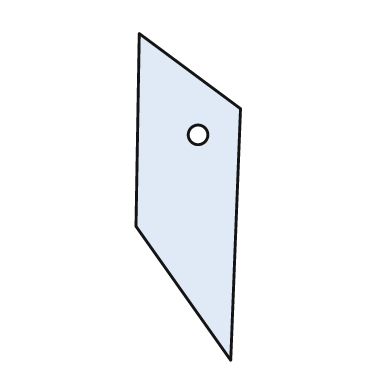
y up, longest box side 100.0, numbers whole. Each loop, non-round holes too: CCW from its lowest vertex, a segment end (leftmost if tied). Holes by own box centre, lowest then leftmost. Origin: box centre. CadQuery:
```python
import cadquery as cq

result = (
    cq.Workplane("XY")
    .moveTo(13.0, -50.0)
    .lineTo(16.0, 27.0)
    .lineTo(-15.0, 50.0)
    .lineTo(-16.0, -9.0)
    .close()
    .moveTo(3.0, 19.0)
    .circle(3.0)
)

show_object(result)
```